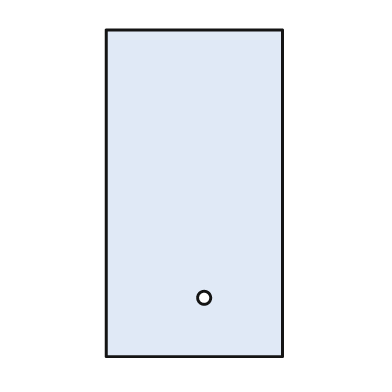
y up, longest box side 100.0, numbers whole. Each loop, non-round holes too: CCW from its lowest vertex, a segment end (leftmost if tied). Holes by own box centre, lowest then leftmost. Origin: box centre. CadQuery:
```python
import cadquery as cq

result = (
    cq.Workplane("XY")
    .moveTo(-27.0, -50.0)
    .lineTo(27.0, -50.0)
    .lineTo(27.0, 50.0)
    .lineTo(-27.0, 50.0)
    .close()
    .moveTo(3.0, -32.0)
    .circle(2.0)
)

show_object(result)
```